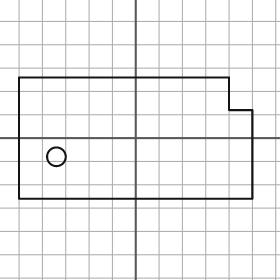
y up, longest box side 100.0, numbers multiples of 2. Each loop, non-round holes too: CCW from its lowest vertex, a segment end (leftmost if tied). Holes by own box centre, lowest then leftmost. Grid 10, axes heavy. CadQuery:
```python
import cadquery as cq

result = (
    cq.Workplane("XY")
    .moveTo(-50.0, -26.0)
    .lineTo(50.0, -26.0)
    .lineTo(50.0, 12.0)
    .lineTo(40.0, 12.0)
    .lineTo(40.0, 26.0)
    .lineTo(-50.0, 26.0)
    .close()
    .moveTo(-34.0, -8.0)
    .circle(4.0)
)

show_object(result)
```